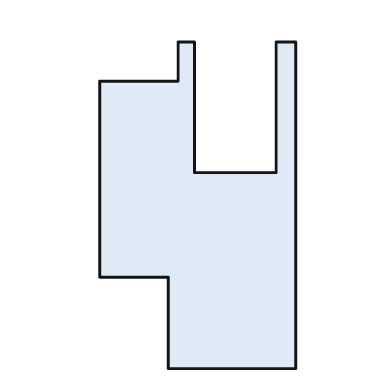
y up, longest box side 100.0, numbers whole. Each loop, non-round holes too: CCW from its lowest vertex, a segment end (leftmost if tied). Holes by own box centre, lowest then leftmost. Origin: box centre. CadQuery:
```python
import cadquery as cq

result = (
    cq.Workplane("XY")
    .moveTo(-9.0, -50.0)
    .lineTo(30.0, -50.0)
    .lineTo(30.0, 50.0)
    .lineTo(24.0, 50.0)
    .lineTo(24.0, 10.0)
    .lineTo(-1.0, 10.0)
    .lineTo(-1.0, 50.0)
    .lineTo(-6.0, 50.0)
    .lineTo(-6.0, 38.0)
    .lineTo(-30.0, 38.0)
    .lineTo(-30.0, -22.0)
    .lineTo(-9.0, -22.0)
    .close()
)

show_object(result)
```